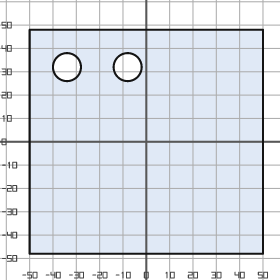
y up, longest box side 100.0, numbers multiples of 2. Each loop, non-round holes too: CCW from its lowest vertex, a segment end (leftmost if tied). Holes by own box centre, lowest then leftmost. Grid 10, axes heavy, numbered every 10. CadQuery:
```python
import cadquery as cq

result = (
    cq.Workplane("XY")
    .moveTo(-50.0, -48.0)
    .lineTo(50.0, -48.0)
    .lineTo(50.0, 48.0)
    .lineTo(-50.0, 48.0)
    .close()
    .moveTo(-34.0, 32.0)
    .circle(6.0)
    .moveTo(-8.0, 32.0)
    .circle(6.0)
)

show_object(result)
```